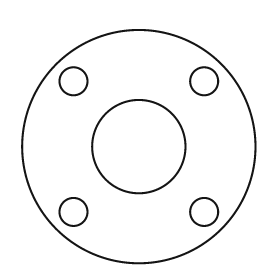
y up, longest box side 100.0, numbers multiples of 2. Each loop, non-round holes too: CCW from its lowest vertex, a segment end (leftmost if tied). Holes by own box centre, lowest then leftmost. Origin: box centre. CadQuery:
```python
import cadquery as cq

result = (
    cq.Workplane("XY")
    .moveTo(0.0, 0.0)
    .circle(50.0)
    .moveTo(-28.0, -28.0)
    .circle(6.0)
    .moveTo(28.0, -28.0)
    .circle(6.0)
    .moveTo(0.0, 0.0)
    .circle(20.0)
    .moveTo(-28.0, 28.0)
    .circle(6.0)
    .moveTo(28.0, 28.0)
    .circle(6.0)
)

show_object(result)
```